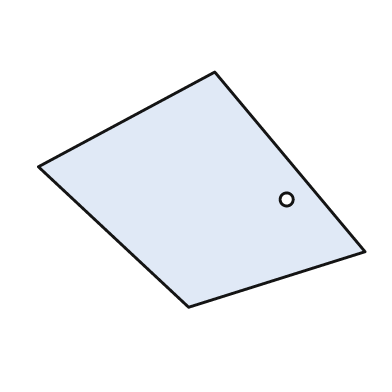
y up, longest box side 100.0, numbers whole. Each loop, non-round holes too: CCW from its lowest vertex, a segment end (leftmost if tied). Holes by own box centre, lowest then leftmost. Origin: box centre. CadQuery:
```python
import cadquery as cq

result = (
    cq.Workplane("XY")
    .moveTo(-4.0, -36.0)
    .lineTo(50.0, -19.0)
    .lineTo(4.0, 36.0)
    .lineTo(-50.0, 7.0)
    .close()
    .moveTo(26.0, -3.0)
    .circle(2.0)
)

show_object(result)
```